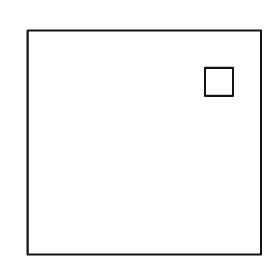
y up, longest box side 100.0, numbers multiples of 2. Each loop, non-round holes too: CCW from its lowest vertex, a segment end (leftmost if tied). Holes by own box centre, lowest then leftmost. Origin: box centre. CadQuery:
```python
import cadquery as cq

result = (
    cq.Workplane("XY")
    .moveTo(-50.0, -48.0)
    .lineTo(50.0, -48.0)
    .lineTo(50.0, 48.0)
    .lineTo(-50.0, 48.0)
    .close()
    .moveTo(26.0, 20.0)
    .lineTo(38.0, 20.0)
    .lineTo(38.0, 32.0)
    .lineTo(26.0, 32.0)
    .close()
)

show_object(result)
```